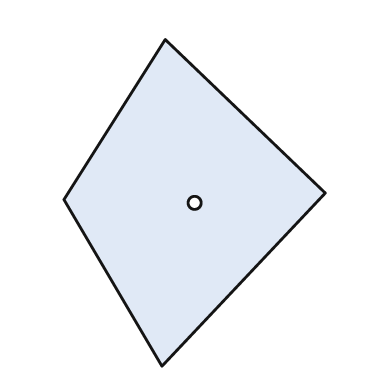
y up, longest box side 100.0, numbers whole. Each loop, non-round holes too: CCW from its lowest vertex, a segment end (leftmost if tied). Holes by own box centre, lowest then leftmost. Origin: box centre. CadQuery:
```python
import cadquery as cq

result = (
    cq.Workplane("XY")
    .moveTo(-10.0, -50.0)
    .lineTo(40.0, 3.0)
    .lineTo(-9.0, 50.0)
    .lineTo(-40.0, 1.0)
    .close()
    .moveTo(0.0, 0.0)
    .circle(2.0)
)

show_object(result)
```